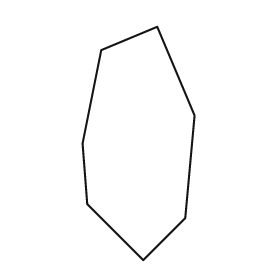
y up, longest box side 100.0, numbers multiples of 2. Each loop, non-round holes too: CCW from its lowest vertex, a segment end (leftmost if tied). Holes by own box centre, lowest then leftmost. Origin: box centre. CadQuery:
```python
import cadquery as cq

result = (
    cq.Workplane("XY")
    .moveTo(2.0, -50.0)
    .lineTo(20.0, -32.0)
    .lineTo(24.0, 12.0)
    .lineTo(8.0, 50.0)
    .lineTo(-16.0, 40.0)
    .lineTo(-24.0, 0.0)
    .lineTo(-22.0, -26.0)
    .close()
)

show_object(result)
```